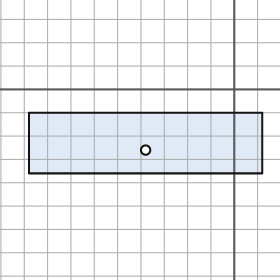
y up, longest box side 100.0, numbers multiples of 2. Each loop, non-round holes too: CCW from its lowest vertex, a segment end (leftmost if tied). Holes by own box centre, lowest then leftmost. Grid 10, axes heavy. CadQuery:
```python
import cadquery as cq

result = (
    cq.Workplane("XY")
    .moveTo(-88.0, -36.0)
    .lineTo(12.0, -36.0)
    .lineTo(12.0, -10.0)
    .lineTo(-88.0, -10.0)
    .close()
    .moveTo(-38.0, -26.0)
    .circle(2.0)
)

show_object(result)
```